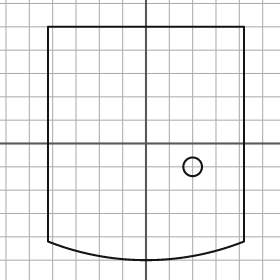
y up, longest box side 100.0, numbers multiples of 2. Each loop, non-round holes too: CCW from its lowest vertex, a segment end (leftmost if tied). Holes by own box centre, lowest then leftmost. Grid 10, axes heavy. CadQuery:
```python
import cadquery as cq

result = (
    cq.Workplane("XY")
    .moveTo(-42.0, -42.0)
    .threePointArc((0.0, -50.0), (42.0, -42.0))
    .lineTo(42.0, 50.0)
    .lineTo(-42.0, 50.0)
    .close()
    .moveTo(20.0, -10.0)
    .circle(4.0)
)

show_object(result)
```